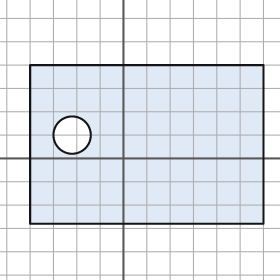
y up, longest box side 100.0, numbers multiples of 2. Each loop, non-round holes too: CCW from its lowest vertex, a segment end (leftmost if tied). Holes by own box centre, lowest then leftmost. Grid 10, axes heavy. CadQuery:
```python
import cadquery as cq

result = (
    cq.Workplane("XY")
    .moveTo(-40.0, -28.0)
    .lineTo(60.0, -28.0)
    .lineTo(60.0, 40.0)
    .lineTo(-40.0, 40.0)
    .close()
    .moveTo(-22.0, 10.0)
    .circle(8.0)
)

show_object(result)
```